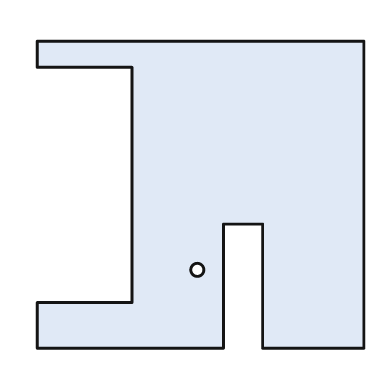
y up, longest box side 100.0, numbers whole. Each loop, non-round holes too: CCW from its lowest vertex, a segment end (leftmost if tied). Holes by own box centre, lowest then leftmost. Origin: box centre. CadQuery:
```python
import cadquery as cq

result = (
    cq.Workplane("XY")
    .moveTo(-50.0, -47.0)
    .lineTo(7.0, -47.0)
    .lineTo(7.0, -9.0)
    .lineTo(19.0, -9.0)
    .lineTo(19.0, -47.0)
    .lineTo(50.0, -47.0)
    .lineTo(50.0, 47.0)
    .lineTo(-50.0, 47.0)
    .lineTo(-50.0, 39.0)
    .lineTo(-21.0, 39.0)
    .lineTo(-21.0, -33.0)
    .lineTo(-50.0, -33.0)
    .close()
    .moveTo(-1.0, -23.0)
    .circle(2.0)
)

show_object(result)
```